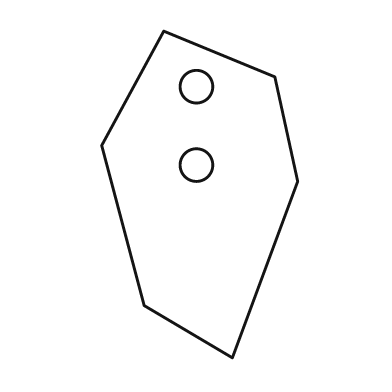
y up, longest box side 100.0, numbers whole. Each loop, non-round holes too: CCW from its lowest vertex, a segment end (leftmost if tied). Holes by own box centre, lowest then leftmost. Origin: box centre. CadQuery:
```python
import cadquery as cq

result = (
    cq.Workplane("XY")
    .moveTo(10.0, -50.0)
    .lineTo(30.0, 4.0)
    .lineTo(23.0, 36.0)
    .lineTo(-11.0, 50.0)
    .lineTo(-30.0, 15.0)
    .lineTo(-17.0, -34.0)
    .close()
    .moveTo(-1.0, 9.0)
    .circle(5.0)
    .moveTo(-1.0, 33.0)
    .circle(5.0)
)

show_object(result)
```